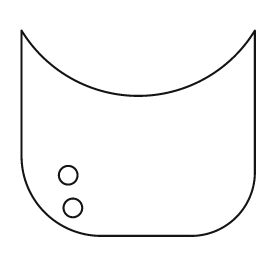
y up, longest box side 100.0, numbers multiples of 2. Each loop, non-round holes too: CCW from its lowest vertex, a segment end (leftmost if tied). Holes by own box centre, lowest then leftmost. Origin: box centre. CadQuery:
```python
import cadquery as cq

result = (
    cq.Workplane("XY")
    .moveTo(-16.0, -44.0)
    .lineTo(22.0, -44.0)
    .threePointArc((42.0, -36.0), (50.0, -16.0))
    .lineTo(50.0, 44.0)
    .threePointArc((0.0, 16.0), (-50.0, 44.0))
    .lineTo(-50.0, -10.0)
    .threePointArc((-40.0, -34.0), (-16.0, -44.0))
    .close()
    .moveTo(-28.0, -32.0)
    .circle(4.0)
    .moveTo(-30.0, -18.0)
    .circle(4.0)
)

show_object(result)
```